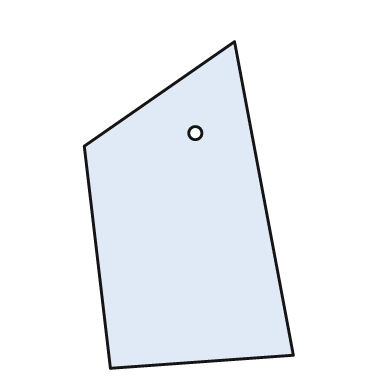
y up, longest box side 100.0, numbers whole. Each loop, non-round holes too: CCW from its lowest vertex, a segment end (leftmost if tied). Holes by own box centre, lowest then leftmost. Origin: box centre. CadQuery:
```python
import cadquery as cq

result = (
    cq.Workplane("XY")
    .moveTo(-24.0, -50.0)
    .lineTo(32.0, -46.0)
    .lineTo(14.0, 50.0)
    .lineTo(-32.0, 18.0)
    .close()
    .moveTo(2.0, 22.0)
    .circle(2.0)
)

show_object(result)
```